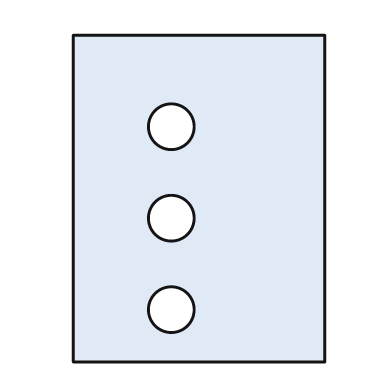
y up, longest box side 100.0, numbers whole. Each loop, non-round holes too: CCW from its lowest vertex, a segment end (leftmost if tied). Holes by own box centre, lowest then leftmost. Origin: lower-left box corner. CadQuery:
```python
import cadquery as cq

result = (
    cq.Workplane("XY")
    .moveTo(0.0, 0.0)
    .lineTo(77.0, 0.0)
    .lineTo(77.0, 100.0)
    .lineTo(0.0, 100.0)
    .close()
    .moveTo(30.0, 16.0)
    .circle(7.0)
    .moveTo(30.0, 44.0)
    .circle(7.0)
    .moveTo(30.0, 72.0)
    .circle(7.0)
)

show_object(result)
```